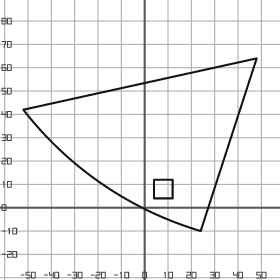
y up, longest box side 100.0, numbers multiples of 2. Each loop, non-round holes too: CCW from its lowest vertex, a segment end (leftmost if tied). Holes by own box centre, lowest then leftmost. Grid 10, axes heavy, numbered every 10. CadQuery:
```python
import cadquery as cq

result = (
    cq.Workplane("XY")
    .moveTo(24.0, -10.0)
    .lineTo(48.0, 64.0)
    .lineTo(-52.0, 42.0)
    .threePointArc((-18.0, 10.0), (24.0, -10.0))
    .close()
    .moveTo(4.0, 4.0)
    .lineTo(12.0, 4.0)
    .lineTo(12.0, 12.0)
    .lineTo(4.0, 12.0)
    .close()
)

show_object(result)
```